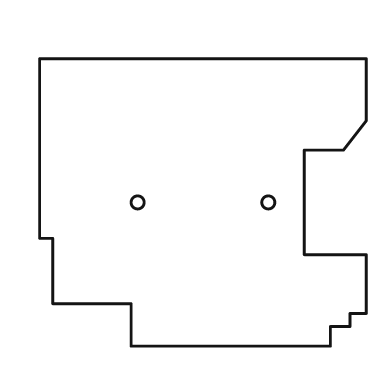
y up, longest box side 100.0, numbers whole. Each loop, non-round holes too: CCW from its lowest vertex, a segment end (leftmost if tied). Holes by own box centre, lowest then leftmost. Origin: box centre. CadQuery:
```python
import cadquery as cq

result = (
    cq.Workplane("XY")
    .moveTo(-22.0, -44.0)
    .lineTo(39.0, -44.0)
    .lineTo(39.0, -38.0)
    .lineTo(45.0, -38.0)
    .lineTo(45.0, -34.0)
    .lineTo(50.0, -34.0)
    .lineTo(50.0, -16.0)
    .lineTo(31.0, -16.0)
    .lineTo(31.0, 16.0)
    .lineTo(43.0, 16.0)
    .lineTo(50.0, 25.0)
    .lineTo(50.0, 44.0)
    .lineTo(-50.0, 44.0)
    .lineTo(-50.0, -11.0)
    .lineTo(-46.0, -11.0)
    .lineTo(-46.0, -31.0)
    .lineTo(-22.0, -31.0)
    .close()
    .moveTo(-20.0, 0.0)
    .circle(2.0)
    .moveTo(20.0, 0.0)
    .circle(2.0)
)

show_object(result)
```